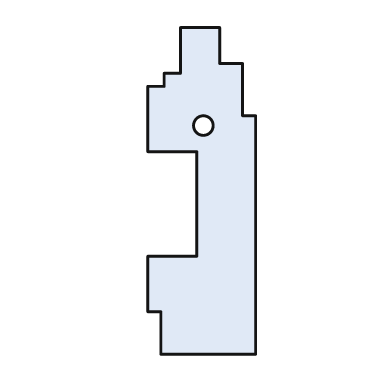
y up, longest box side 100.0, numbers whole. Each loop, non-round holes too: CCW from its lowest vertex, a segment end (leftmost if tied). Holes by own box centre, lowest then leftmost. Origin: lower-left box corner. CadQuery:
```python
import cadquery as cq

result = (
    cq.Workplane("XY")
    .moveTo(4.0, 0.0)
    .lineTo(33.0, 0.0)
    .lineTo(33.0, 73.0)
    .lineTo(29.0, 73.0)
    .lineTo(29.0, 89.0)
    .lineTo(22.0, 89.0)
    .lineTo(22.0, 100.0)
    .lineTo(10.0, 100.0)
    .lineTo(10.0, 86.0)
    .lineTo(5.0, 86.0)
    .lineTo(5.0, 82.0)
    .lineTo(0.0, 82.0)
    .lineTo(0.0, 62.0)
    .lineTo(15.0, 62.0)
    .lineTo(15.0, 30.0)
    .lineTo(0.0, 30.0)
    .lineTo(0.0, 13.0)
    .lineTo(4.0, 13.0)
    .close()
    .moveTo(17.0, 70.0)
    .circle(3.0)
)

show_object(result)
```